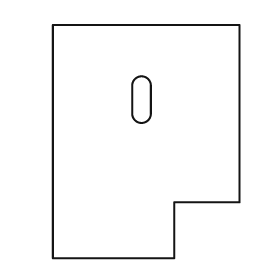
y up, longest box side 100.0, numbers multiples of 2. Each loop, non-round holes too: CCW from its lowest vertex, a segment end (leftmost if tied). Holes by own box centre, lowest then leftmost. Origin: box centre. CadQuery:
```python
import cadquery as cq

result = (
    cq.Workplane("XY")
    .moveTo(-40.0, -50.0)
    .lineTo(12.0, -50.0)
    .lineTo(12.0, -26.0)
    .lineTo(40.0, -26.0)
    .lineTo(40.0, 50.0)
    .lineTo(-40.0, 50.0)
    .close()
    .moveTo(-6.0, 12.0)
    .threePointArc((-2.0, 8.0), (2.0, 12.0))
    .lineTo(2.0, 24.0)
    .threePointArc((-2.0, 28.0), (-6.0, 24.0))
    .close()
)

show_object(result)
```